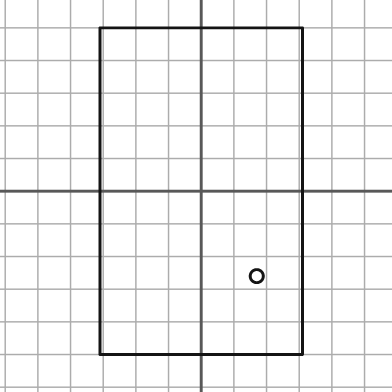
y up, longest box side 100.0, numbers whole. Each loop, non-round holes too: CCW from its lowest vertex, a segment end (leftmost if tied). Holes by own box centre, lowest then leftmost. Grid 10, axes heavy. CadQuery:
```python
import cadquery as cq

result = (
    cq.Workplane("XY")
    .moveTo(-31.0, -50.0)
    .lineTo(31.0, -50.0)
    .lineTo(31.0, 50.0)
    .lineTo(-31.0, 50.0)
    .close()
    .moveTo(17.0, -26.0)
    .circle(2.0)
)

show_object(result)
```